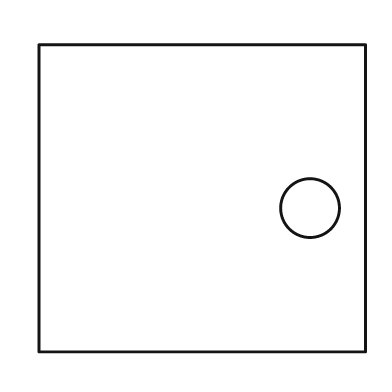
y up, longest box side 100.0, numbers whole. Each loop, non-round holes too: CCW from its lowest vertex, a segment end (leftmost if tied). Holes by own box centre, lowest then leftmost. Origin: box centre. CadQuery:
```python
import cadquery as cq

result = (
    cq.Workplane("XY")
    .moveTo(-50.0, -47.0)
    .lineTo(50.0, -47.0)
    .lineTo(50.0, 47.0)
    .lineTo(-50.0, 47.0)
    .close()
    .moveTo(33.0, -3.0)
    .circle(9.0)
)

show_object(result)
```